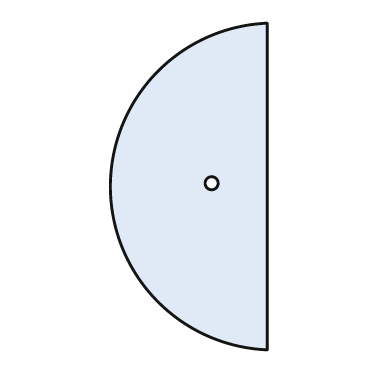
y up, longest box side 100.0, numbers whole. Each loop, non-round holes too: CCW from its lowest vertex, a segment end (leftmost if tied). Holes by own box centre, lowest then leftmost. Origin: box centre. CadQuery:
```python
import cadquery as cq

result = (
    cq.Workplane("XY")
    .moveTo(24.0, -50.0)
    .lineTo(24.0, 50.0)
    .threePointArc((-24.0, 0.0), (24.0, -50.0))
    .close()
    .moveTo(7.0, 1.0)
    .circle(2.0)
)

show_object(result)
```